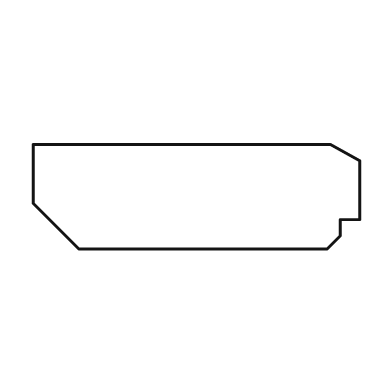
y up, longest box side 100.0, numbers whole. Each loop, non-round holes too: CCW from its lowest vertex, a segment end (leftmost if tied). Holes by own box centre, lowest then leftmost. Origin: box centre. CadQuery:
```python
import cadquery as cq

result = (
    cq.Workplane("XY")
    .moveTo(-36.0, -16.0)
    .lineTo(40.0, -16.0)
    .lineTo(44.0, -12.0)
    .lineTo(44.0, -7.0)
    .lineTo(50.0, -7.0)
    .lineTo(50.0, 11.0)
    .lineTo(41.0, 16.0)
    .lineTo(-50.0, 16.0)
    .lineTo(-50.0, -2.0)
    .close()
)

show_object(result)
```